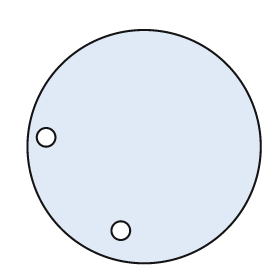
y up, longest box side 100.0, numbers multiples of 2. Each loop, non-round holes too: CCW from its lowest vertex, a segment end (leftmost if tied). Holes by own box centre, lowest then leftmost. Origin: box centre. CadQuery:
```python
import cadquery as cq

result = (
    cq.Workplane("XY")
    .moveTo(0.0, 0.0)
    .circle(50.0)
    .moveTo(-10.0, -36.0)
    .circle(4.0)
    .moveTo(-42.0, 4.0)
    .circle(4.0)
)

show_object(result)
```